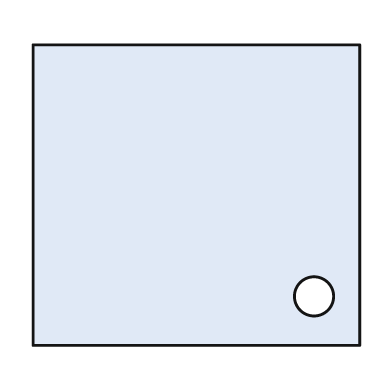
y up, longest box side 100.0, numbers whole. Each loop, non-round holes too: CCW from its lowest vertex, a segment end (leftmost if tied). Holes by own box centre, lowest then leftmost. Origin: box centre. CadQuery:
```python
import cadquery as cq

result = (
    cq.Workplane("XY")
    .moveTo(-50.0, -46.0)
    .lineTo(50.0, -46.0)
    .lineTo(50.0, 46.0)
    .lineTo(-50.0, 46.0)
    .close()
    .moveTo(36.0, -31.0)
    .circle(6.0)
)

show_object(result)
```